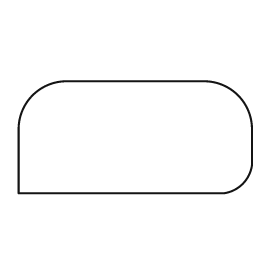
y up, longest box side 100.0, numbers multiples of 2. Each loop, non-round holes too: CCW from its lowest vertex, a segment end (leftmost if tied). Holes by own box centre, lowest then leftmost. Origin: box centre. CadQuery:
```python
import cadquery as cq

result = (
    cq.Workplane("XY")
    .moveTo(-50.0, -24.0)
    .lineTo(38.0, -24.0)
    .threePointArc((46.0, -20.0), (50.0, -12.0))
    .lineTo(50.0, 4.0)
    .threePointArc((44.0, 18.0), (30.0, 24.0))
    .lineTo(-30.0, 24.0)
    .threePointArc((-44.0, 18.0), (-50.0, 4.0))
    .close()
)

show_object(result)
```